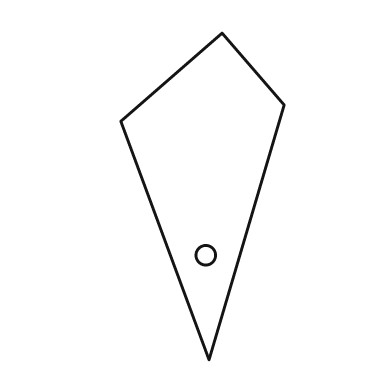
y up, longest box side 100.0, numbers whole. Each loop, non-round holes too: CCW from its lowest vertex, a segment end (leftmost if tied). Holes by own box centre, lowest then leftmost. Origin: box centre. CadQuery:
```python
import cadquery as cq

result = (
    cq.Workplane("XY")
    .moveTo(2.0, -50.0)
    .lineTo(25.0, 28.0)
    .lineTo(6.0, 50.0)
    .lineTo(-25.0, 23.0)
    .close()
    .moveTo(1.0, -18.0)
    .circle(3.0)
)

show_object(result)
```